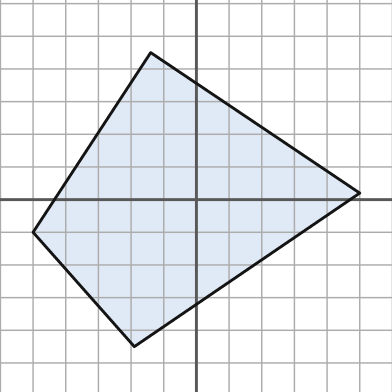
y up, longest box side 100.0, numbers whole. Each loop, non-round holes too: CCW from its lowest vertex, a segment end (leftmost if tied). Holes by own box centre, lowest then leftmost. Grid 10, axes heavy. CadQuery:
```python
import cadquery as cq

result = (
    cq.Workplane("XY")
    .moveTo(-19.0, -45.0)
    .lineTo(50.0, 2.0)
    .lineTo(-14.0, 45.0)
    .lineTo(-50.0, -10.0)
    .close()
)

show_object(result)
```